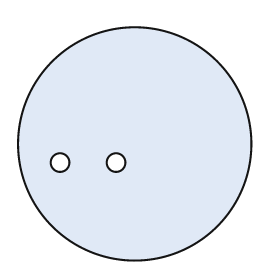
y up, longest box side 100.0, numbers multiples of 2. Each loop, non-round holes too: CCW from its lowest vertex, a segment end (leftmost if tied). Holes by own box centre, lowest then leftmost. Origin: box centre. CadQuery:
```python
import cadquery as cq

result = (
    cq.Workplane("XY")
    .moveTo(0.0, 0.0)
    .circle(50.0)
    .moveTo(-32.0, -8.0)
    .circle(4.0)
    .moveTo(-8.0, -8.0)
    .circle(4.0)
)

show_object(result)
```